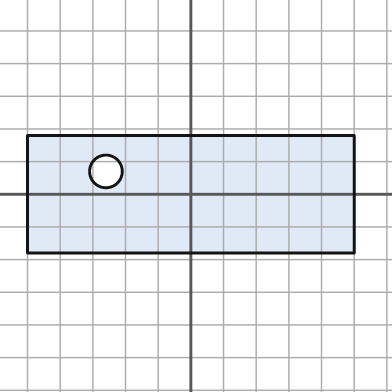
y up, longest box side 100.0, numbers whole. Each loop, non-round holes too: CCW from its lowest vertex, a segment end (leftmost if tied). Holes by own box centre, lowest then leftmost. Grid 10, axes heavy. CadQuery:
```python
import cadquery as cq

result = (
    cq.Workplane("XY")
    .moveTo(-50.0, -18.0)
    .lineTo(50.0, -18.0)
    .lineTo(50.0, 18.0)
    .lineTo(-50.0, 18.0)
    .close()
    .moveTo(-26.0, 7.0)
    .circle(5.0)
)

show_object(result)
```